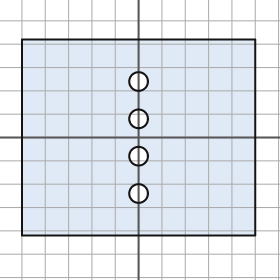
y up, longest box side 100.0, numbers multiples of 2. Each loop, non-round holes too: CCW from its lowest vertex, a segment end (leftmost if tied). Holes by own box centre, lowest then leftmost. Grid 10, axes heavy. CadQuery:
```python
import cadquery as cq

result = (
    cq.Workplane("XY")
    .moveTo(-50.0, -42.0)
    .lineTo(50.0, -42.0)
    .lineTo(50.0, 42.0)
    .lineTo(-50.0, 42.0)
    .close()
    .moveTo(0.0, -24.0)
    .circle(4.0)
    .moveTo(0.0, -8.0)
    .circle(4.0)
    .moveTo(0.0, 8.0)
    .circle(4.0)
    .moveTo(0.0, 24.0)
    .circle(4.0)
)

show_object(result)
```